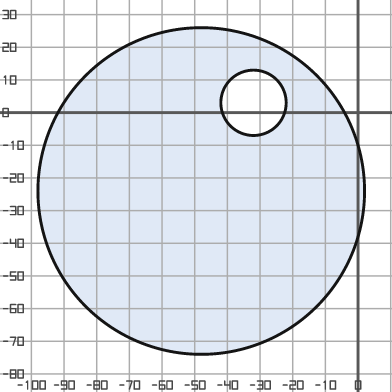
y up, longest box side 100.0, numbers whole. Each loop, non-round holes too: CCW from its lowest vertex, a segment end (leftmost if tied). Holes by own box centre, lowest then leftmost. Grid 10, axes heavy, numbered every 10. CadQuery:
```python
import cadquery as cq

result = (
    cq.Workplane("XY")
    .moveTo(-48.0, -24.0)
    .circle(50.0)
    .moveTo(-32.0, 3.0)
    .circle(10.0)
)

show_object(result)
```